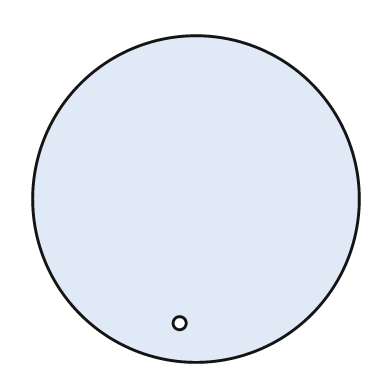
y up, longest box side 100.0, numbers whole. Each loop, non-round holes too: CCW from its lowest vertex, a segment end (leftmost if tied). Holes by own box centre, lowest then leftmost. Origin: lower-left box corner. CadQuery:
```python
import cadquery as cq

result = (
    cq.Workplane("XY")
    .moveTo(50.0, 50.0)
    .circle(50.0)
    .moveTo(45.0, 12.0)
    .circle(2.0)
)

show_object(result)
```